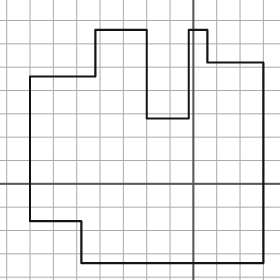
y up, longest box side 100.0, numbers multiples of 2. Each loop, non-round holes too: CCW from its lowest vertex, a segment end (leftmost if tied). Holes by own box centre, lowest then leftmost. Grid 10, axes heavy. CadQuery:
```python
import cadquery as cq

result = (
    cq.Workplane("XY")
    .moveTo(-48.0, -34.0)
    .lineTo(30.0, -34.0)
    .lineTo(30.0, 52.0)
    .lineTo(6.0, 52.0)
    .lineTo(6.0, 66.0)
    .lineTo(-2.0, 66.0)
    .lineTo(-2.0, 28.0)
    .lineTo(-20.0, 28.0)
    .lineTo(-20.0, 66.0)
    .lineTo(-42.0, 66.0)
    .lineTo(-42.0, 46.0)
    .lineTo(-70.0, 46.0)
    .lineTo(-70.0, -16.0)
    .lineTo(-48.0, -16.0)
    .close()
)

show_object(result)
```